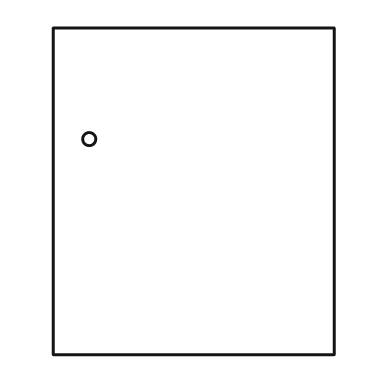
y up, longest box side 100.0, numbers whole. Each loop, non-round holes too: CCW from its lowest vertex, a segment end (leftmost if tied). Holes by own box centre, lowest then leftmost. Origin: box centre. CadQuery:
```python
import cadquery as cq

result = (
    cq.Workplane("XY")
    .moveTo(-43.0, -50.0)
    .lineTo(43.0, -50.0)
    .lineTo(43.0, 50.0)
    .lineTo(-43.0, 50.0)
    .close()
    .moveTo(-32.0, 16.0)
    .circle(2.0)
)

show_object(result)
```